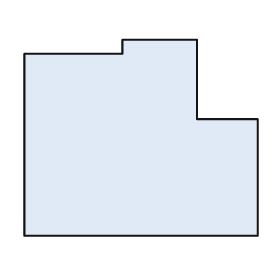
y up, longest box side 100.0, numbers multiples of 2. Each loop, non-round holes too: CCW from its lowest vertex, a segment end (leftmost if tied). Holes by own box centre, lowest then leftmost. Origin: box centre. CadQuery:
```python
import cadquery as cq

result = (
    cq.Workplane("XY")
    .moveTo(-50.0, -42.0)
    .lineTo(50.0, -42.0)
    .lineTo(50.0, 8.0)
    .lineTo(24.0, 8.0)
    .lineTo(24.0, 42.0)
    .lineTo(-8.0, 42.0)
    .lineTo(-8.0, 36.0)
    .lineTo(-50.0, 36.0)
    .close()
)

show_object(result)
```